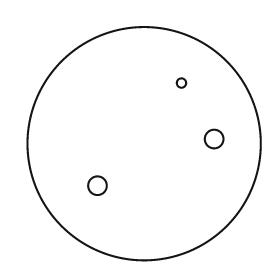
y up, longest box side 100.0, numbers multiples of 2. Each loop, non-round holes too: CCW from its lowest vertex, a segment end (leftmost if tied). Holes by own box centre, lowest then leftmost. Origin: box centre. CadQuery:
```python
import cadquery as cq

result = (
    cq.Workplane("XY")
    .moveTo(0.0, 0.0)
    .circle(50.0)
    .moveTo(-20.0, -18.0)
    .circle(4.0)
    .moveTo(30.0, 2.0)
    .circle(4.0)
    .moveTo(16.0, 26.0)
    .circle(2.0)
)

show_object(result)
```